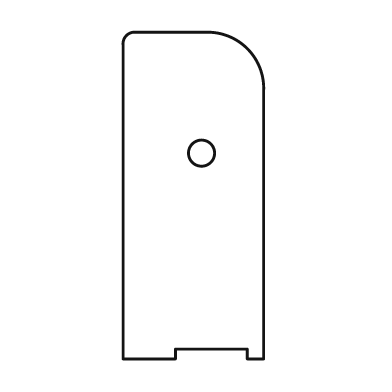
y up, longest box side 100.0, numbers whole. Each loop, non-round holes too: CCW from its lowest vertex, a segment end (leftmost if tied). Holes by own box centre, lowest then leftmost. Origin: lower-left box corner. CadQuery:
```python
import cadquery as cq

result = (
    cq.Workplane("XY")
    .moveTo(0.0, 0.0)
    .lineTo(16.0, 0.0)
    .lineTo(16.0, 3.0)
    .lineTo(38.0, 3.0)
    .lineTo(38.0, 0.0)
    .lineTo(43.0, 0.0)
    .lineTo(43.0, 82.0)
    .threePointArc((38.0, 95.0), (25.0, 100.0))
    .lineTo(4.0, 100.0)
    .threePointArc((1.0, 99.0), (0.0, 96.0))
    .close()
    .moveTo(24.0, 63.0)
    .circle(4.0)
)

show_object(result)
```